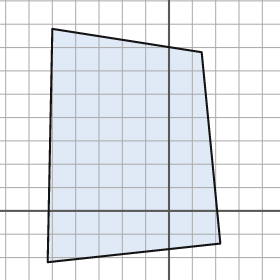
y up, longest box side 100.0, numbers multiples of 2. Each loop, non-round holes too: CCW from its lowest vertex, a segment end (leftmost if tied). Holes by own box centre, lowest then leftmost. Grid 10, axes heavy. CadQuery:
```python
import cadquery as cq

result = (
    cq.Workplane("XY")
    .moveTo(-52.0, -22.0)
    .lineTo(22.0, -14.0)
    .lineTo(14.0, 68.0)
    .lineTo(-50.0, 78.0)
    .close()
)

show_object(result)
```